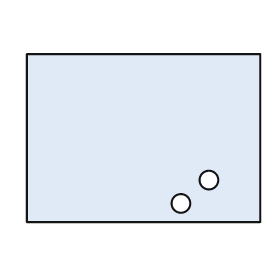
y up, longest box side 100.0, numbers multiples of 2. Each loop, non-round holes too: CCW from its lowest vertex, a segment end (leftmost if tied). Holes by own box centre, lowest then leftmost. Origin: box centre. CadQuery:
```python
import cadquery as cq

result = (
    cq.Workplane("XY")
    .moveTo(-50.0, -36.0)
    .lineTo(50.0, -36.0)
    .lineTo(50.0, 36.0)
    .lineTo(-50.0, 36.0)
    .close()
    .moveTo(16.0, -28.0)
    .circle(4.0)
    .moveTo(28.0, -18.0)
    .circle(4.0)
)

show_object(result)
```